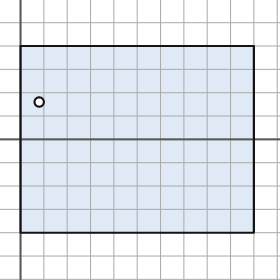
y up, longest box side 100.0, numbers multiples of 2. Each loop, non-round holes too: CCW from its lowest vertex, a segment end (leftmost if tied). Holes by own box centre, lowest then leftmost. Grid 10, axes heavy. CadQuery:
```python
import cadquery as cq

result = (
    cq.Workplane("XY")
    .moveTo(0.0, -40.0)
    .lineTo(100.0, -40.0)
    .lineTo(100.0, 40.0)
    .lineTo(0.0, 40.0)
    .close()
    .moveTo(8.0, 16.0)
    .circle(2.0)
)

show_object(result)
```